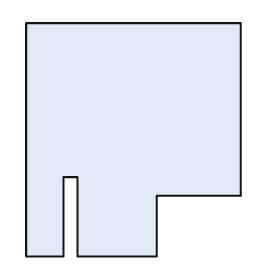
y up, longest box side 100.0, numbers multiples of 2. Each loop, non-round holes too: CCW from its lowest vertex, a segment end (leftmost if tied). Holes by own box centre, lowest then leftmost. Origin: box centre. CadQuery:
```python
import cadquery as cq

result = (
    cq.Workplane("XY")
    .moveTo(-46.0, -50.0)
    .lineTo(-30.0, -50.0)
    .lineTo(-30.0, -16.0)
    .lineTo(-24.0, -16.0)
    .lineTo(-24.0, -50.0)
    .lineTo(10.0, -50.0)
    .lineTo(10.0, -24.0)
    .lineTo(46.0, -24.0)
    .lineTo(46.0, 50.0)
    .lineTo(-46.0, 50.0)
    .close()
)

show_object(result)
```